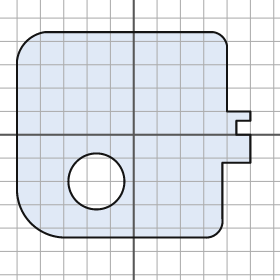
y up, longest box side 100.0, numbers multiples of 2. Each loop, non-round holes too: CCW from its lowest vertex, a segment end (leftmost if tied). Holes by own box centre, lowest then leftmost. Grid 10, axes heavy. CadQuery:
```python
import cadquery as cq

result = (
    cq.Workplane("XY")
    .moveTo(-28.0, -44.0)
    .lineTo(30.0, -44.0)
    .threePointArc((36.0, -42.0), (38.0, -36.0))
    .lineTo(38.0, -12.0)
    .lineTo(50.0, -12.0)
    .lineTo(50.0, 0.0)
    .lineTo(44.0, 0.0)
    .lineTo(44.0, 6.0)
    .lineTo(50.0, 6.0)
    .lineTo(50.0, 10.0)
    .lineTo(40.0, 10.0)
    .lineTo(40.0, 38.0)
    .threePointArc((38.0, 42.0), (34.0, 44.0))
    .lineTo(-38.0, 44.0)
    .threePointArc((-46.0, 40.0), (-50.0, 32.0))
    .lineTo(-50.0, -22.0)
    .threePointArc((-44.0, -38.0), (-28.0, -44.0))
    .close()
    .moveTo(-16.0, -20.0)
    .circle(12.0)
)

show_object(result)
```